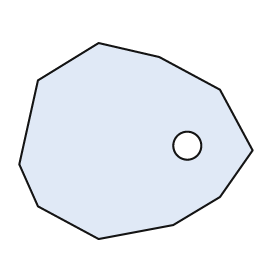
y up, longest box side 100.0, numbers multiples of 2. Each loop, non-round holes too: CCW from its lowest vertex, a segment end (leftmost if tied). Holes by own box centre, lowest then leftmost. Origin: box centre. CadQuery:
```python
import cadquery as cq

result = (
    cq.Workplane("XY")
    .moveTo(-16.0, -42.0)
    .lineTo(16.0, -36.0)
    .lineTo(36.0, -24.0)
    .lineTo(50.0, -4.0)
    .lineTo(36.0, 22.0)
    .lineTo(10.0, 36.0)
    .lineTo(-16.0, 42.0)
    .lineTo(-42.0, 26.0)
    .lineTo(-50.0, -10.0)
    .lineTo(-42.0, -28.0)
    .close()
    .moveTo(22.0, -2.0)
    .circle(6.0)
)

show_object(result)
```